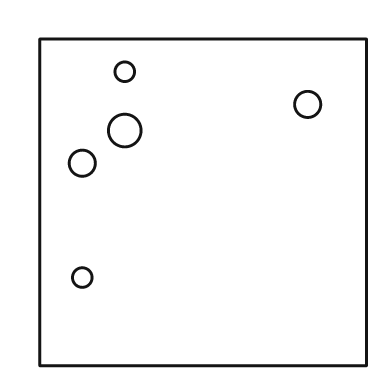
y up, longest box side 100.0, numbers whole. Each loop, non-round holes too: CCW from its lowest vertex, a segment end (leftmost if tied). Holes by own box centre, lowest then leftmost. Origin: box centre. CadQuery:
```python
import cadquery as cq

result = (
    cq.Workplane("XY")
    .moveTo(-50.0, -50.0)
    .lineTo(50.0, -50.0)
    .lineTo(50.0, 50.0)
    .lineTo(-50.0, 50.0)
    .close()
    .moveTo(-37.0, -23.0)
    .circle(3.0)
    .moveTo(-37.0, 12.0)
    .circle(4.0)
    .moveTo(-24.0, 22.0)
    .circle(5.0)
    .moveTo(32.0, 30.0)
    .circle(4.0)
    .moveTo(-24.0, 40.0)
    .circle(3.0)
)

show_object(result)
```